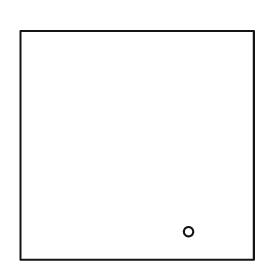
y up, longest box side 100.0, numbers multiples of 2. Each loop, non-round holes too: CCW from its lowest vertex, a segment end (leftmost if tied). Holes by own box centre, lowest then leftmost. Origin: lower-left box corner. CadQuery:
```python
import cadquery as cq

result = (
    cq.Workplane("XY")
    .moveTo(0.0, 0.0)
    .lineTo(100.0, 0.0)
    .lineTo(100.0, 98.0)
    .lineTo(0.0, 98.0)
    .close()
    .moveTo(72.0, 12.0)
    .circle(2.0)
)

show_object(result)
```